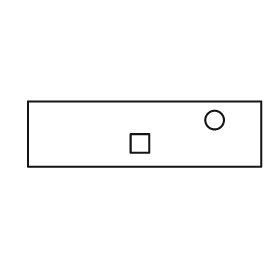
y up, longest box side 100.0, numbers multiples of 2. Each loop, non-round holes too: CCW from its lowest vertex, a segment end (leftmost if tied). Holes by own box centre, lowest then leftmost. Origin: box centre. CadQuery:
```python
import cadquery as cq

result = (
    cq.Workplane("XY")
    .moveTo(-50.0, -14.0)
    .lineTo(50.0, -14.0)
    .lineTo(50.0, 14.0)
    .lineTo(-50.0, 14.0)
    .close()
    .moveTo(-6.0, -8.0)
    .lineTo(2.0, -8.0)
    .lineTo(2.0, 0.0)
    .lineTo(-6.0, 0.0)
    .close()
    .moveTo(30.0, 6.0)
    .circle(4.0)
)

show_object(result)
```